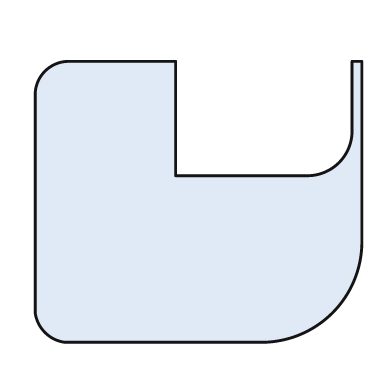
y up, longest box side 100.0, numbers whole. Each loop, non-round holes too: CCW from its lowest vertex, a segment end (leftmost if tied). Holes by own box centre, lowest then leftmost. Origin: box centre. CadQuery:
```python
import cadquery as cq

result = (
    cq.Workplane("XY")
    .moveTo(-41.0, -43.0)
    .lineTo(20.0, -43.0)
    .threePointArc((41.0, -34.0), (50.0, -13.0))
    .lineTo(50.0, 43.0)
    .lineTo(47.0, 43.0)
    .lineTo(47.0, 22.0)
    .threePointArc((43.0, 12.0), (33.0, 8.0))
    .lineTo(-7.0, 8.0)
    .lineTo(-7.0, 43.0)
    .lineTo(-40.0, 43.0)
    .threePointArc((-47.0, 40.0), (-50.0, 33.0))
    .lineTo(-50.0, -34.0)
    .threePointArc((-47.0, -40.0), (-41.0, -43.0))
    .close()
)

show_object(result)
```